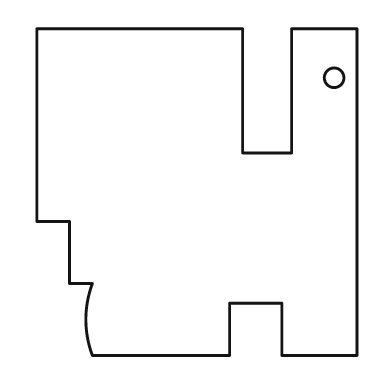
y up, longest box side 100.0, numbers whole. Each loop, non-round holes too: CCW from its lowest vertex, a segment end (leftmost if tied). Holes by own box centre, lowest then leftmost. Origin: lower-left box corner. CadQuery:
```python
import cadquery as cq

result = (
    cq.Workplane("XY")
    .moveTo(17.0, 0.0)
    .lineTo(59.0, 0.0)
    .lineTo(59.0, 16.0)
    .lineTo(75.0, 16.0)
    .lineTo(75.0, 0.0)
    .lineTo(98.0, 0.0)
    .lineTo(98.0, 100.0)
    .lineTo(78.0, 100.0)
    .lineTo(78.0, 62.0)
    .lineTo(63.0, 62.0)
    .lineTo(63.0, 100.0)
    .lineTo(0.0, 100.0)
    .lineTo(0.0, 41.0)
    .lineTo(10.0, 41.0)
    .lineTo(10.0, 22.0)
    .lineTo(17.0, 22.0)
    .threePointArc((15.0, 11.0), (17.0, 0.0))
    .close()
    .moveTo(91.0, 85.0)
    .circle(3.0)
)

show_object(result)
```